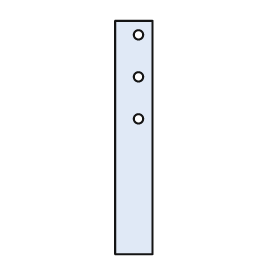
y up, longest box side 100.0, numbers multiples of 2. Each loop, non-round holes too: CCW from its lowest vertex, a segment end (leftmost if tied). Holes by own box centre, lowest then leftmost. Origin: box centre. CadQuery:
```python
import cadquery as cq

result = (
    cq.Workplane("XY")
    .moveTo(-8.0, -50.0)
    .lineTo(8.0, -50.0)
    .lineTo(8.0, 50.0)
    .lineTo(-8.0, 50.0)
    .close()
    .moveTo(2.0, 8.0)
    .circle(2.0)
    .moveTo(2.0, 26.0)
    .circle(2.0)
    .moveTo(2.0, 44.0)
    .circle(2.0)
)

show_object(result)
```